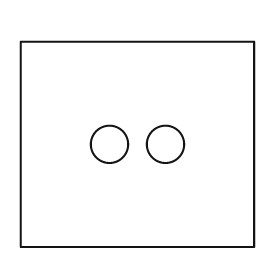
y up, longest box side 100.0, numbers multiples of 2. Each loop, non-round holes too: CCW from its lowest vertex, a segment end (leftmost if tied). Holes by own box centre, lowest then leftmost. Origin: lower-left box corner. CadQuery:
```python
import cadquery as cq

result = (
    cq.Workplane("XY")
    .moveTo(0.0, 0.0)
    .lineTo(100.0, 0.0)
    .lineTo(100.0, 88.0)
    .lineTo(0.0, 88.0)
    .close()
    .moveTo(38.0, 44.0)
    .circle(8.0)
    .moveTo(62.0, 44.0)
    .circle(8.0)
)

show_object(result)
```